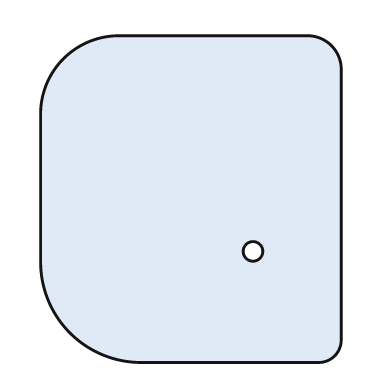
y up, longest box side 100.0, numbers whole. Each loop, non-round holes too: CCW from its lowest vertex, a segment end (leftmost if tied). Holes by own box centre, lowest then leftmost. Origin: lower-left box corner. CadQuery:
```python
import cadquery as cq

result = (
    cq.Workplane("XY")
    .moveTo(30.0, 0.0)
    .lineTo(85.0, 0.0)
    .threePointArc((90.0, 2.0), (92.0, 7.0))
    .lineTo(92.0, 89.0)
    .threePointArc((89.0, 97.0), (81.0, 100.0))
    .lineTo(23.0, 100.0)
    .threePointArc((7.0, 93.0), (0.0, 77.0))
    .lineTo(0.0, 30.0)
    .threePointArc((9.0, 9.0), (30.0, 0.0))
    .close()
    .moveTo(65.0, 34.0)
    .circle(3.0)
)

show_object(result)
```